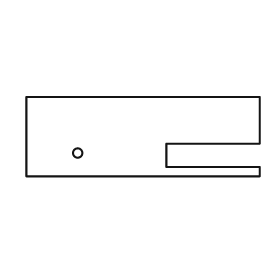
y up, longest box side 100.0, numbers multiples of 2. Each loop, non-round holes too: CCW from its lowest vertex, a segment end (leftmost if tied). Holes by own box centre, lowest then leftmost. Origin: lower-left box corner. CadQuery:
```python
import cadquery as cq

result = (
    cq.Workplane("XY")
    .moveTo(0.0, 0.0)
    .lineTo(100.0, 0.0)
    .lineTo(100.0, 4.0)
    .lineTo(60.0, 4.0)
    .lineTo(60.0, 14.0)
    .lineTo(100.0, 14.0)
    .lineTo(100.0, 34.0)
    .lineTo(0.0, 34.0)
    .close()
    .moveTo(22.0, 10.0)
    .circle(2.0)
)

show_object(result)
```